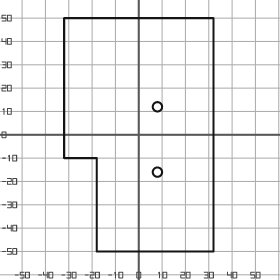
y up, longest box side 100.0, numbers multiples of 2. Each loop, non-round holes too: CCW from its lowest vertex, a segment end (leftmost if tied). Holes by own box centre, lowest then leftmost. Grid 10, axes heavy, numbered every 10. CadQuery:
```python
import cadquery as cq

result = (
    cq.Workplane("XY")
    .moveTo(-18.0, -50.0)
    .lineTo(32.0, -50.0)
    .lineTo(32.0, 50.0)
    .lineTo(-32.0, 50.0)
    .lineTo(-32.0, -10.0)
    .lineTo(-18.0, -10.0)
    .close()
    .moveTo(8.0, -16.0)
    .circle(2.0)
    .moveTo(8.0, 12.0)
    .circle(2.0)
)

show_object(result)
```